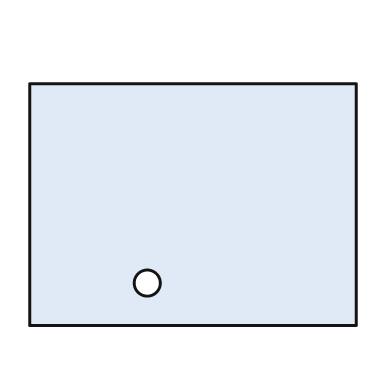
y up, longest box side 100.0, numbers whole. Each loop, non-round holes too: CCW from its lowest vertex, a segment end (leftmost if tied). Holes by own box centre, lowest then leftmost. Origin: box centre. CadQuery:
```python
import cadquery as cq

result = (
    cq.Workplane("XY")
    .moveTo(-50.0, -37.0)
    .lineTo(50.0, -37.0)
    .lineTo(50.0, 37.0)
    .lineTo(-50.0, 37.0)
    .close()
    .moveTo(-14.0, -24.0)
    .circle(4.0)
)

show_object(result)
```